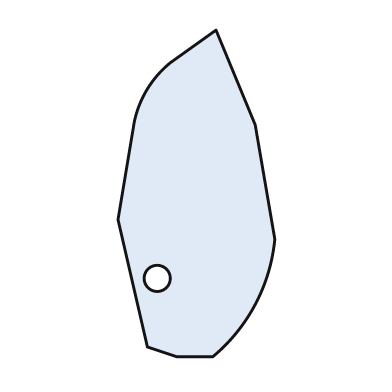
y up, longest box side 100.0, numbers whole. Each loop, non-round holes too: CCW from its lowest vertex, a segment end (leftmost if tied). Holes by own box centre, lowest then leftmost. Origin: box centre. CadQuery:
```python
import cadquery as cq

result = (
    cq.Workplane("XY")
    .moveTo(-6.0, -50.0)
    .lineTo(5.0, -50.0)
    .threePointArc((18.0, -34.0), (24.0, -14.0))
    .lineTo(18.0, 21.0)
    .lineTo(6.0, 50.0)
    .lineTo(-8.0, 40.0)
    .threePointArc((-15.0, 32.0), (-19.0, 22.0))
    .lineTo(-24.0, -8.0)
    .lineTo(-15.0, -47.0)
    .close()
    .moveTo(-12.0, -26.0)
    .circle(4.0)
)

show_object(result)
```